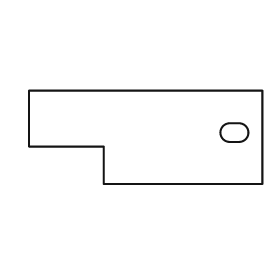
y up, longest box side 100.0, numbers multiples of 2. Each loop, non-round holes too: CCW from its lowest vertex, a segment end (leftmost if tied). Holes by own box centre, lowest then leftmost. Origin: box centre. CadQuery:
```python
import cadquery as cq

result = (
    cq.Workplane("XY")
    .moveTo(-18.0, -20.0)
    .lineTo(50.0, -20.0)
    .lineTo(50.0, 20.0)
    .lineTo(-50.0, 20.0)
    .lineTo(-50.0, -4.0)
    .lineTo(-18.0, -4.0)
    .close()
    .moveTo(36.0, -2.0)
    .lineTo(40.0, -2.0)
    .threePointArc((44.0, 2.0), (40.0, 6.0))
    .lineTo(36.0, 6.0)
    .threePointArc((32.0, 2.0), (36.0, -2.0))
    .close()
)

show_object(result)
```